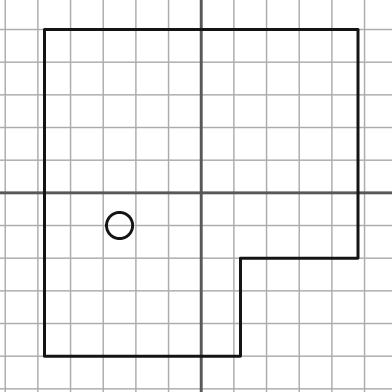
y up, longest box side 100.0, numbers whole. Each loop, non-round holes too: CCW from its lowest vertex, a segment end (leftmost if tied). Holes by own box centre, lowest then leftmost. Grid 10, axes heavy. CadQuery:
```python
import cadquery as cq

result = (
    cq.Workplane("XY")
    .moveTo(-48.0, -50.0)
    .lineTo(12.0, -50.0)
    .lineTo(12.0, -20.0)
    .lineTo(48.0, -20.0)
    .lineTo(48.0, 50.0)
    .lineTo(-48.0, 50.0)
    .close()
    .moveTo(-25.0, -10.0)
    .circle(4.0)
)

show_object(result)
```